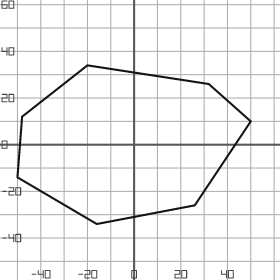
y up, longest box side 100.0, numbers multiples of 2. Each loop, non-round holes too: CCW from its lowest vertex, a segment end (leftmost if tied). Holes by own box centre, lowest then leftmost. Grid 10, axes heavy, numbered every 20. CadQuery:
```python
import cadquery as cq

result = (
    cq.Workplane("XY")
    .moveTo(-16.0, -34.0)
    .lineTo(26.0, -26.0)
    .lineTo(50.0, 10.0)
    .lineTo(32.0, 26.0)
    .lineTo(-20.0, 34.0)
    .lineTo(-48.0, 12.0)
    .lineTo(-50.0, -14.0)
    .close()
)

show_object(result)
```